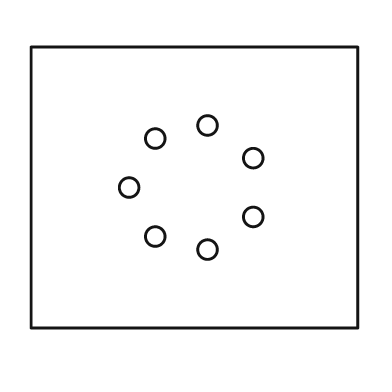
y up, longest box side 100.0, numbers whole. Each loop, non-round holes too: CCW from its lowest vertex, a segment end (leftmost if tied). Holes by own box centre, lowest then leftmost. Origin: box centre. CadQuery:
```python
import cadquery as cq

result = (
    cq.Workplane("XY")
    .moveTo(-50.0, -43.0)
    .lineTo(50.0, -43.0)
    .lineTo(50.0, 43.0)
    .lineTo(-50.0, 43.0)
    .close()
    .moveTo(4.0, -19.0)
    .circle(3.0)
    .moveTo(-12.0, -15.0)
    .circle(3.0)
    .moveTo(18.0, -9.0)
    .circle(3.0)
    .moveTo(-20.0, 0.0)
    .circle(3.0)
    .moveTo(18.0, 9.0)
    .circle(3.0)
    .moveTo(-12.0, 15.0)
    .circle(3.0)
    .moveTo(4.0, 19.0)
    .circle(3.0)
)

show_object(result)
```